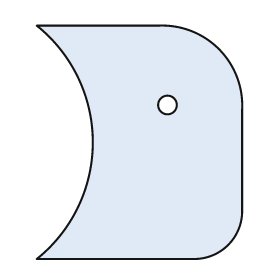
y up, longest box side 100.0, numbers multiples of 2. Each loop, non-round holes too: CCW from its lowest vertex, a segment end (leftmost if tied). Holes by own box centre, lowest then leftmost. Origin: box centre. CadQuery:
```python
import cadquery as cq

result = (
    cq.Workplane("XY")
    .moveTo(-44.0, -50.0)
    .lineTo(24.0, -50.0)
    .threePointArc((38.0, -44.0), (44.0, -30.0))
    .lineTo(44.0, 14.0)
    .threePointArc((34.0, 40.0), (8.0, 50.0))
    .lineTo(-44.0, 50.0)
    .threePointArc((-20.0, 0.0), (-44.0, -50.0))
    .close()
    .moveTo(12.0, 16.0)
    .circle(4.0)
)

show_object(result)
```